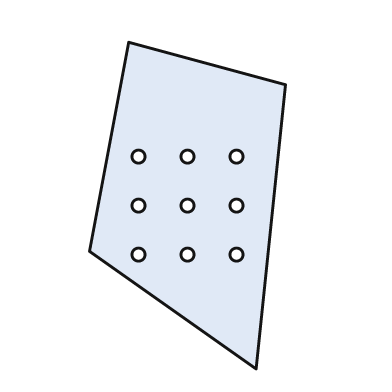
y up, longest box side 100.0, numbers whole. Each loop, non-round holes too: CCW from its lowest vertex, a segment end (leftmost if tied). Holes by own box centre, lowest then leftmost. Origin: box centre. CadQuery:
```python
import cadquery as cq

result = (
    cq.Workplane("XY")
    .moveTo(21.0, -50.0)
    .lineTo(30.0, 37.0)
    .lineTo(-18.0, 50.0)
    .lineTo(-30.0, -14.0)
    .close()
    .moveTo(-15.0, -15.0)
    .circle(2.0)
    .moveTo(0.0, -15.0)
    .circle(2.0)
    .moveTo(15.0, -15.0)
    .circle(2.0)
    .moveTo(-15.0, 0.0)
    .circle(2.0)
    .moveTo(0.0, 0.0)
    .circle(2.0)
    .moveTo(15.0, 0.0)
    .circle(2.0)
    .moveTo(-15.0, 15.0)
    .circle(2.0)
    .moveTo(0.0, 15.0)
    .circle(2.0)
    .moveTo(15.0, 15.0)
    .circle(2.0)
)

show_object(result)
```